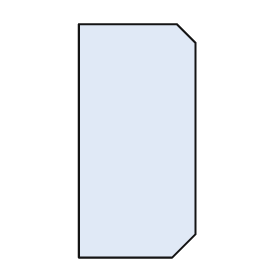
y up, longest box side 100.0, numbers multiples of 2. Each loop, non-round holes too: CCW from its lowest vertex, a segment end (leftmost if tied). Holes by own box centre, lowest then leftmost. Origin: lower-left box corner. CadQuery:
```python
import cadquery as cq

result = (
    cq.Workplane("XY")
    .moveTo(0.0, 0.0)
    .lineTo(40.0, 0.0)
    .lineTo(50.0, 10.0)
    .lineTo(50.0, 92.0)
    .lineTo(42.0, 100.0)
    .lineTo(0.0, 100.0)
    .close()
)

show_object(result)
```